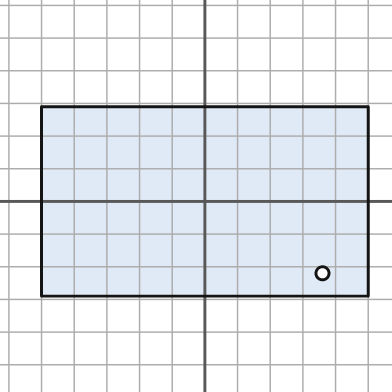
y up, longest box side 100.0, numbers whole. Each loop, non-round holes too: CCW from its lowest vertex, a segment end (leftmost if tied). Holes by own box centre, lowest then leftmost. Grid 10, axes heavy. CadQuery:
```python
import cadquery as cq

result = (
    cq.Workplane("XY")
    .moveTo(-50.0, -29.0)
    .lineTo(50.0, -29.0)
    .lineTo(50.0, 29.0)
    .lineTo(-50.0, 29.0)
    .close()
    .moveTo(36.0, -22.0)
    .circle(2.0)
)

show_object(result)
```